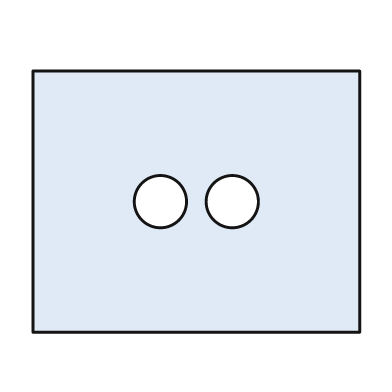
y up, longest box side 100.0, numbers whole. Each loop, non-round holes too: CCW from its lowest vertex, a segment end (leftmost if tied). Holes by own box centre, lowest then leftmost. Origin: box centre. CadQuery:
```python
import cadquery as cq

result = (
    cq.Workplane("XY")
    .moveTo(-50.0, -40.0)
    .lineTo(50.0, -40.0)
    .lineTo(50.0, 40.0)
    .lineTo(-50.0, 40.0)
    .close()
    .moveTo(-11.0, 0.0)
    .circle(8.0)
    .moveTo(11.0, 0.0)
    .circle(8.0)
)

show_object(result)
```